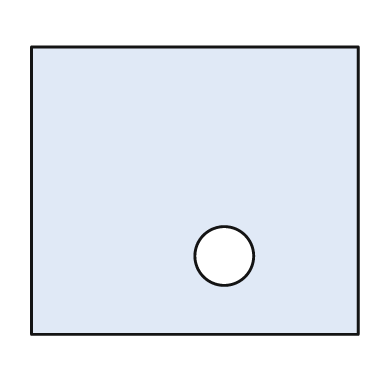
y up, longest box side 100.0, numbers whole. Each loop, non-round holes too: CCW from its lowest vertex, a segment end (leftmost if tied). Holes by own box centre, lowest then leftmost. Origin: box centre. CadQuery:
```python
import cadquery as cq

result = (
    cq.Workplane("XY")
    .moveTo(-50.0, -44.0)
    .lineTo(50.0, -44.0)
    .lineTo(50.0, 44.0)
    .lineTo(-50.0, 44.0)
    .close()
    .moveTo(9.0, -20.0)
    .circle(9.0)
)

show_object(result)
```